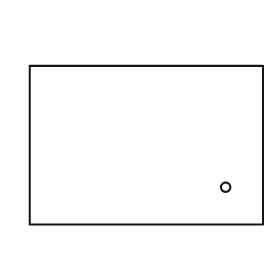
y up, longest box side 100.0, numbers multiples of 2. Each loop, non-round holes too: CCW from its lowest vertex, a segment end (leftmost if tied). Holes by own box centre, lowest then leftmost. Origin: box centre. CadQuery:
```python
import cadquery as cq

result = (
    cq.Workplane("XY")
    .moveTo(-50.0, -34.0)
    .lineTo(50.0, -34.0)
    .lineTo(50.0, 34.0)
    .lineTo(-50.0, 34.0)
    .close()
    .moveTo(34.0, -18.0)
    .circle(2.0)
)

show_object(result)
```